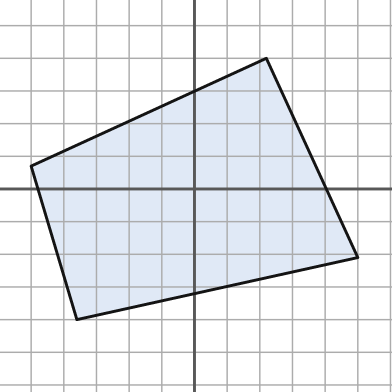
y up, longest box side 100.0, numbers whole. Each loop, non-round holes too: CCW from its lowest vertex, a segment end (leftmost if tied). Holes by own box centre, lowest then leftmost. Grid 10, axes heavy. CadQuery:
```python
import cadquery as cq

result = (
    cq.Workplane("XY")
    .moveTo(-36.0, -40.0)
    .lineTo(50.0, -21.0)
    .lineTo(22.0, 40.0)
    .lineTo(-50.0, 7.0)
    .close()
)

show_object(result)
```